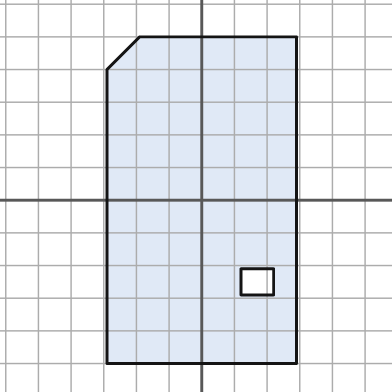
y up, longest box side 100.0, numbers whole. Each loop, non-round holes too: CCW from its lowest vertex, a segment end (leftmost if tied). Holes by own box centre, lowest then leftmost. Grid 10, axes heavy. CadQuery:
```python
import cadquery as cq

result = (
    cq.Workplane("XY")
    .moveTo(-29.0, -50.0)
    .lineTo(29.0, -50.0)
    .lineTo(29.0, 50.0)
    .lineTo(-19.0, 50.0)
    .lineTo(-29.0, 40.0)
    .close()
    .moveTo(12.0, -29.0)
    .lineTo(22.0, -29.0)
    .lineTo(22.0, -21.0)
    .lineTo(12.0, -21.0)
    .close()
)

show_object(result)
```